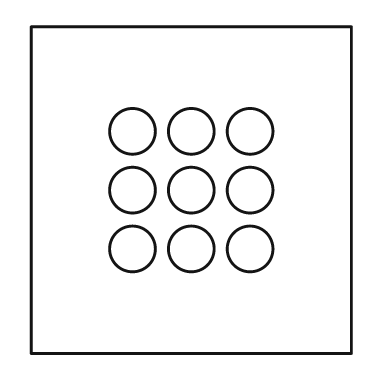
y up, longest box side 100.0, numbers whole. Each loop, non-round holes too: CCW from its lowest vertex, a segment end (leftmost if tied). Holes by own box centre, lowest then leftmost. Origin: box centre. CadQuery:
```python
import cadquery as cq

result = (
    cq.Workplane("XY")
    .moveTo(-49.0, -50.0)
    .lineTo(49.0, -50.0)
    .lineTo(49.0, 50.0)
    .lineTo(-49.0, 50.0)
    .close()
    .moveTo(-18.0, -18.0)
    .circle(7.0)
    .moveTo(0.0, -18.0)
    .circle(7.0)
    .moveTo(18.0, -18.0)
    .circle(7.0)
    .moveTo(-18.0, 0.0)
    .circle(7.0)
    .moveTo(0.0, 0.0)
    .circle(7.0)
    .moveTo(18.0, 0.0)
    .circle(7.0)
    .moveTo(-18.0, 18.0)
    .circle(7.0)
    .moveTo(0.0, 18.0)
    .circle(7.0)
    .moveTo(18.0, 18.0)
    .circle(7.0)
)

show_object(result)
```